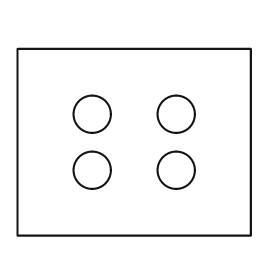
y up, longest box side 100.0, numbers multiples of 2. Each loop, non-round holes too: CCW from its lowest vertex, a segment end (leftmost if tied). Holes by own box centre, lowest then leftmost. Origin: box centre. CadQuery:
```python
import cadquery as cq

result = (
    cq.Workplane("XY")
    .moveTo(-50.0, -40.0)
    .lineTo(50.0, -40.0)
    .lineTo(50.0, 40.0)
    .lineTo(-50.0, 40.0)
    .close()
    .moveTo(-18.0, -12.0)
    .circle(8.0)
    .moveTo(18.0, -12.0)
    .circle(8.0)
    .moveTo(-18.0, 12.0)
    .circle(8.0)
    .moveTo(18.0, 12.0)
    .circle(8.0)
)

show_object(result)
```